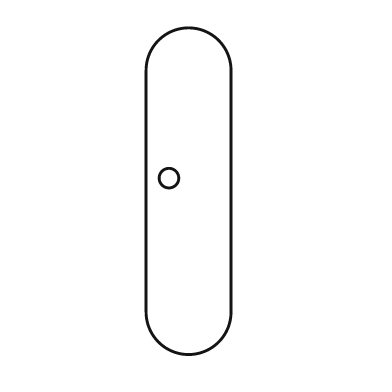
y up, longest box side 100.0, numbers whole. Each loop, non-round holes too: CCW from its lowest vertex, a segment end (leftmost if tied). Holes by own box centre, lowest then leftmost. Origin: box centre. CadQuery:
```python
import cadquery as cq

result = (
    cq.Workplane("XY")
    .moveTo(-13.0, -37.0)
    .threePointArc((0.0, -50.0), (13.0, -37.0))
    .lineTo(13.0, 37.0)
    .threePointArc((0.0, 50.0), (-13.0, 37.0))
    .close()
    .moveTo(-6.0, 4.0)
    .circle(3.0)
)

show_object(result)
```